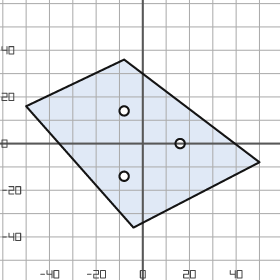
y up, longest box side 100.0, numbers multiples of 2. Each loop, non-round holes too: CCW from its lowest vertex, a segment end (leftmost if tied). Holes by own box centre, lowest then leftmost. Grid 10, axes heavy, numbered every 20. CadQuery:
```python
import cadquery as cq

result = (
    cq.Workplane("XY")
    .moveTo(-4.0, -36.0)
    .lineTo(50.0, -8.0)
    .lineTo(-8.0, 36.0)
    .lineTo(-50.0, 16.0)
    .close()
    .moveTo(-8.0, -14.0)
    .circle(2.0)
    .moveTo(16.0, 0.0)
    .circle(2.0)
    .moveTo(-8.0, 14.0)
    .circle(2.0)
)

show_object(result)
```